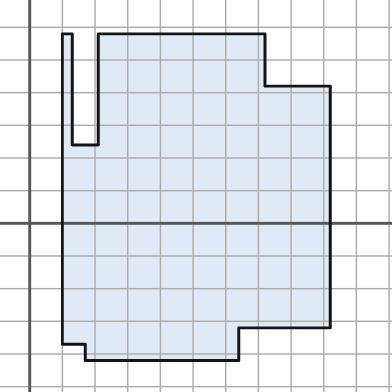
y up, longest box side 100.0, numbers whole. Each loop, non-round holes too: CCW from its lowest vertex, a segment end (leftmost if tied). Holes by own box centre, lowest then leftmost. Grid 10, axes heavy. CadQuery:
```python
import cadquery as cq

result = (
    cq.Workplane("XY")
    .moveTo(17.0, -42.0)
    .lineTo(64.0, -42.0)
    .lineTo(64.0, -32.0)
    .lineTo(92.0, -32.0)
    .lineTo(92.0, 42.0)
    .lineTo(72.0, 42.0)
    .lineTo(72.0, 58.0)
    .lineTo(21.0, 58.0)
    .lineTo(21.0, 24.0)
    .lineTo(13.0, 24.0)
    .lineTo(13.0, 58.0)
    .lineTo(10.0, 58.0)
    .lineTo(10.0, -37.0)
    .lineTo(17.0, -37.0)
    .close()
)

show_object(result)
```